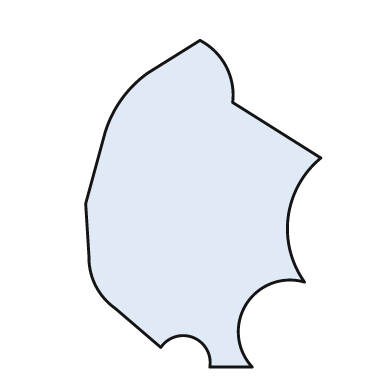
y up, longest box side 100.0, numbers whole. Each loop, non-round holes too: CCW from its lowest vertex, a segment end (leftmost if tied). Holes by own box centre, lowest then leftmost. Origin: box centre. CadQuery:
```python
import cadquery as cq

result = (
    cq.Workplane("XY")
    .moveTo(2.0, -50.0)
    .lineTo(15.0, -50.0)
    .threePointArc((13.0, -31.0), (31.0, -24.0))
    .threePointArc((26.0, -4.0), (36.0, 14.0))
    .lineTo(9.0, 31.0)
    .threePointArc((7.0, 42.0), (-1.0, 50.0))
    .lineTo(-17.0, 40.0)
    .threePointArc((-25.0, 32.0), (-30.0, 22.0))
    .lineTo(-36.0, 0.0)
    .lineTo(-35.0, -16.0)
    .threePointArc((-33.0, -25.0), (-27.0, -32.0))
    .lineTo(-13.0, -44.0)
    .threePointArc((-3.0, -41.0), (2.0, -50.0))
    .close()
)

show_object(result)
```